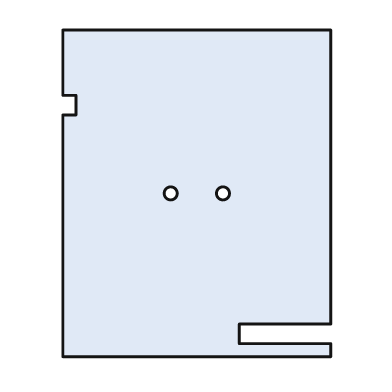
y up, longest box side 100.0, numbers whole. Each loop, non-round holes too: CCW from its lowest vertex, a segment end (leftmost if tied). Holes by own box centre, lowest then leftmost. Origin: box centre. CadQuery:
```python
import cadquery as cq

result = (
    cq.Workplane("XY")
    .moveTo(-41.0, -50.0)
    .lineTo(41.0, -50.0)
    .lineTo(41.0, -46.0)
    .lineTo(13.0, -46.0)
    .lineTo(13.0, -40.0)
    .lineTo(41.0, -40.0)
    .lineTo(41.0, 50.0)
    .lineTo(-41.0, 50.0)
    .lineTo(-41.0, 30.0)
    .lineTo(-37.0, 30.0)
    .lineTo(-37.0, 24.0)
    .lineTo(-41.0, 24.0)
    .close()
    .moveTo(-8.0, 0.0)
    .circle(2.0)
    .moveTo(8.0, 0.0)
    .circle(2.0)
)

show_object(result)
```